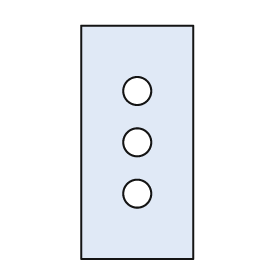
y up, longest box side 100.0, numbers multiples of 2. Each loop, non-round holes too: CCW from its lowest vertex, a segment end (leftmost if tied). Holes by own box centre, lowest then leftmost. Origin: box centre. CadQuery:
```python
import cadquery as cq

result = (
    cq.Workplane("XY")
    .moveTo(-24.0, -50.0)
    .lineTo(24.0, -50.0)
    .lineTo(24.0, 50.0)
    .lineTo(-24.0, 50.0)
    .close()
    .moveTo(0.0, -22.0)
    .circle(6.0)
    .moveTo(0.0, 0.0)
    .circle(6.0)
    .moveTo(0.0, 22.0)
    .circle(6.0)
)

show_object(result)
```